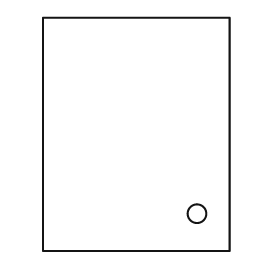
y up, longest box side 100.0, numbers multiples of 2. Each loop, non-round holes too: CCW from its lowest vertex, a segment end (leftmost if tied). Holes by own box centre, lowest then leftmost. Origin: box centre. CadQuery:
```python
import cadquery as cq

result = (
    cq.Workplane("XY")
    .moveTo(-40.0, -50.0)
    .lineTo(40.0, -50.0)
    .lineTo(40.0, 50.0)
    .lineTo(-40.0, 50.0)
    .close()
    .moveTo(26.0, -34.0)
    .circle(4.0)
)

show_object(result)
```